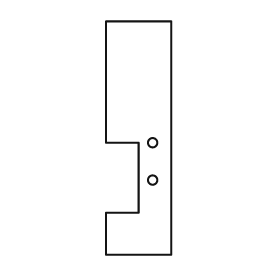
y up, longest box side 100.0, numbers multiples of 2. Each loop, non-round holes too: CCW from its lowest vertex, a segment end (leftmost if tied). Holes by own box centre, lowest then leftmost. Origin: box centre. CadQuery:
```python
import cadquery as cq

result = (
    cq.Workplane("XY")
    .moveTo(-14.0, -50.0)
    .lineTo(14.0, -50.0)
    .lineTo(14.0, 50.0)
    .lineTo(-14.0, 50.0)
    .lineTo(-14.0, -2.0)
    .lineTo(0.0, -2.0)
    .lineTo(0.0, -32.0)
    .lineTo(-14.0, -32.0)
    .close()
    .moveTo(6.0, -18.0)
    .circle(2.0)
    .moveTo(6.0, -2.0)
    .circle(2.0)
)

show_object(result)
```